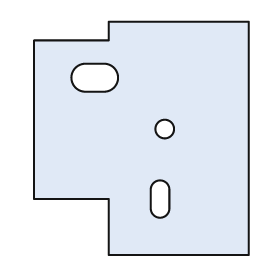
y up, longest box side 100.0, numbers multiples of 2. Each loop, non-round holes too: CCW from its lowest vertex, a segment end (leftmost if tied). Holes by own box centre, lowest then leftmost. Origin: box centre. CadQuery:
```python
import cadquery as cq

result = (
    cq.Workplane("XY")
    .moveTo(-14.0, -50.0)
    .lineTo(46.0, -50.0)
    .lineTo(46.0, 50.0)
    .lineTo(-14.0, 50.0)
    .lineTo(-14.0, 42.0)
    .lineTo(-46.0, 42.0)
    .lineTo(-46.0, -26.0)
    .lineTo(-14.0, -26.0)
    .close()
    .moveTo(4.0, -30.0)
    .threePointArc((8.0, -34.0), (12.0, -30.0))
    .lineTo(12.0, -22.0)
    .threePointArc((8.0, -18.0), (4.0, -22.0))
    .close()
    .moveTo(10.0, 4.0)
    .circle(4.0)
    .moveTo(-24.0, 20.0)
    .lineTo(-16.0, 20.0)
    .threePointArc((-10.0, 26.0), (-16.0, 32.0))
    .lineTo(-24.0, 32.0)
    .threePointArc((-30.0, 26.0), (-24.0, 20.0))
    .close()
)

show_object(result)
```